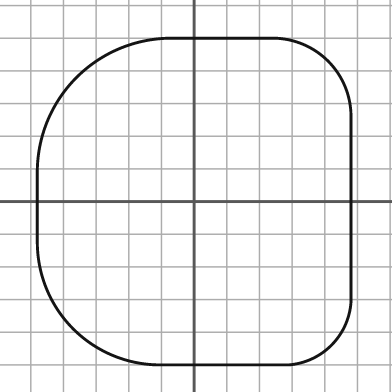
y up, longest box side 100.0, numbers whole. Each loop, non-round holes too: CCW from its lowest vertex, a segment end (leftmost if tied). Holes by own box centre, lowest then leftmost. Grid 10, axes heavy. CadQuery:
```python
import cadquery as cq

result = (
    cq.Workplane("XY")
    .moveTo(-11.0, -50.0)
    .lineTo(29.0, -50.0)
    .threePointArc((42.0, -44.0), (48.0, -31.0))
    .lineTo(48.0, 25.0)
    .threePointArc((41.0, 43.0), (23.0, 50.0))
    .lineTo(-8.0, 50.0)
    .threePointArc((-36.0, 38.0), (-48.0, 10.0))
    .lineTo(-48.0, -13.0)
    .threePointArc((-37.0, -39.0), (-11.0, -50.0))
    .close()
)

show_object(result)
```